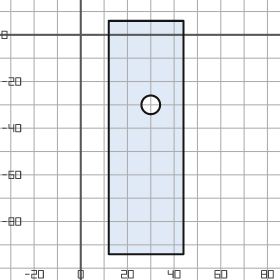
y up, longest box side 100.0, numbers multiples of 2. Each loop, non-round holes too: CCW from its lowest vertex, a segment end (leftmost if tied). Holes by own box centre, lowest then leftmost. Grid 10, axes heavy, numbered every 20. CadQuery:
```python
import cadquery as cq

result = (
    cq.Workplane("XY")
    .moveTo(12.0, -94.0)
    .lineTo(44.0, -94.0)
    .lineTo(44.0, 6.0)
    .lineTo(12.0, 6.0)
    .close()
    .moveTo(30.0, -30.0)
    .circle(4.0)
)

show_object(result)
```